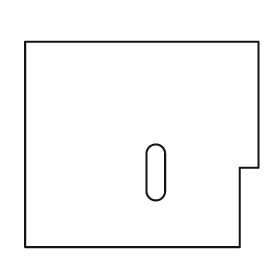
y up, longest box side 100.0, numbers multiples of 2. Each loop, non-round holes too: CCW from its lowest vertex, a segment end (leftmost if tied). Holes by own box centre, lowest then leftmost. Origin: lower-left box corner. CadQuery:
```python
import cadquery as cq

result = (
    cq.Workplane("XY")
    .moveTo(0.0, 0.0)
    .lineTo(92.0, 0.0)
    .lineTo(92.0, 34.0)
    .lineTo(100.0, 34.0)
    .lineTo(100.0, 88.0)
    .lineTo(0.0, 88.0)
    .close()
    .moveTo(52.0, 24.0)
    .threePointArc((56.0, 20.0), (60.0, 24.0))
    .lineTo(60.0, 40.0)
    .threePointArc((56.0, 44.0), (52.0, 40.0))
    .close()
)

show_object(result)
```